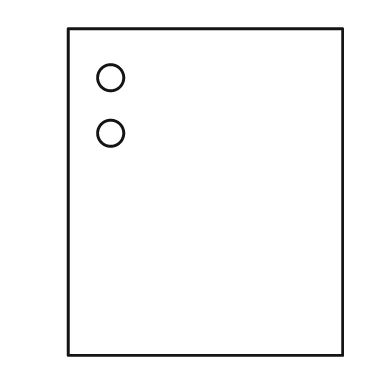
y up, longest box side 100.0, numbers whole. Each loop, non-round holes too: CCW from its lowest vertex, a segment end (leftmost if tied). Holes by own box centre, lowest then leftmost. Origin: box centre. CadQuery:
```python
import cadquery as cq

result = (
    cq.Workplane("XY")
    .moveTo(-42.0, -50.0)
    .lineTo(42.0, -50.0)
    .lineTo(42.0, 50.0)
    .lineTo(-42.0, 50.0)
    .close()
    .moveTo(-29.0, 18.0)
    .circle(4.0)
    .moveTo(-29.0, 35.0)
    .circle(4.0)
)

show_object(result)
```